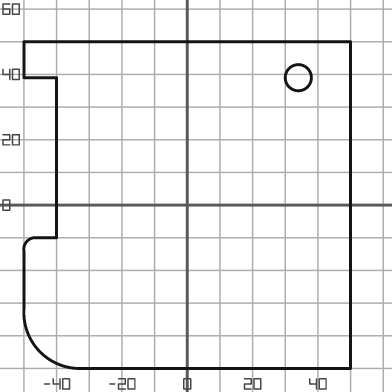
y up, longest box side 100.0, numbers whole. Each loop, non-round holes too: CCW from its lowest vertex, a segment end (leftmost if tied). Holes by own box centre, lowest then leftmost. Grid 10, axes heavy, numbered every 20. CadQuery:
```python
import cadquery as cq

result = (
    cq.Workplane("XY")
    .moveTo(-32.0, -50.0)
    .lineTo(50.0, -50.0)
    .lineTo(50.0, 50.0)
    .lineTo(-50.0, 50.0)
    .lineTo(-50.0, 39.0)
    .lineTo(-40.0, 39.0)
    .lineTo(-40.0, -10.0)
    .lineTo(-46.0, -10.0)
    .threePointArc((-49.0, -11.0), (-50.0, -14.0))
    .lineTo(-50.0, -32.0)
    .threePointArc((-45.0, -45.0), (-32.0, -50.0))
    .close()
    .moveTo(34.0, 39.0)
    .circle(4.0)
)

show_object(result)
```